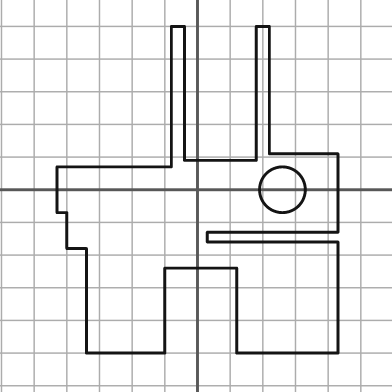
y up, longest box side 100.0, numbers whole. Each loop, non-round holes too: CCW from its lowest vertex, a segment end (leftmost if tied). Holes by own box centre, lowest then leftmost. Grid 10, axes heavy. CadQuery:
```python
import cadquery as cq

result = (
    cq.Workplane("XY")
    .moveTo(-34.0, -50.0)
    .lineTo(-10.0, -50.0)
    .lineTo(-10.0, -24.0)
    .lineTo(12.0, -24.0)
    .lineTo(12.0, -50.0)
    .lineTo(43.0, -50.0)
    .lineTo(43.0, -16.0)
    .lineTo(3.0, -16.0)
    .lineTo(3.0, -13.0)
    .lineTo(43.0, -13.0)
    .lineTo(43.0, 11.0)
    .lineTo(22.0, 11.0)
    .lineTo(22.0, 50.0)
    .lineTo(18.0, 50.0)
    .lineTo(18.0, 9.0)
    .lineTo(-4.0, 9.0)
    .lineTo(-4.0, 50.0)
    .lineTo(-8.0, 50.0)
    .lineTo(-8.0, 7.0)
    .lineTo(-43.0, 7.0)
    .lineTo(-43.0, -7.0)
    .lineTo(-40.0, -7.0)
    .lineTo(-40.0, -18.0)
    .lineTo(-34.0, -18.0)
    .close()
    .moveTo(26.0, 0.0)
    .circle(7.0)
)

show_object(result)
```